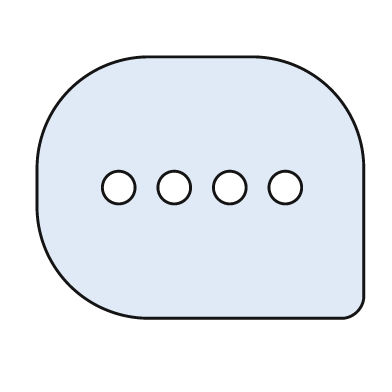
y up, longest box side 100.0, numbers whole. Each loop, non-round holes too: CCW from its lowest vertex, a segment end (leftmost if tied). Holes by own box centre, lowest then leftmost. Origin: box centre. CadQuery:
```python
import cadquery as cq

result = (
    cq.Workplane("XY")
    .moveTo(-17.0, -40.0)
    .lineTo(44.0, -40.0)
    .threePointArc((48.0, -38.0), (50.0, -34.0))
    .lineTo(50.0, 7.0)
    .threePointArc((40.0, 30.0), (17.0, 40.0))
    .lineTo(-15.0, 40.0)
    .threePointArc((-40.0, 30.0), (-50.0, 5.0))
    .lineTo(-50.0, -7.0)
    .threePointArc((-40.0, -30.0), (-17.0, -40.0))
    .close()
    .moveTo(-25.0, 0.0)
    .circle(5.0)
    .moveTo(-8.0, 0.0)
    .circle(5.0)
    .moveTo(9.0, 0.0)
    .circle(5.0)
    .moveTo(26.0, 0.0)
    .circle(5.0)
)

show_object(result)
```